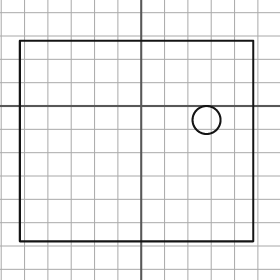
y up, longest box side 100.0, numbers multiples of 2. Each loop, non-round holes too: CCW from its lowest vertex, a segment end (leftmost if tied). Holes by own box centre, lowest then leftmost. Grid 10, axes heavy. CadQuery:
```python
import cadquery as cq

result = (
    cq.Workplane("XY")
    .moveTo(-52.0, -58.0)
    .lineTo(48.0, -58.0)
    .lineTo(48.0, 28.0)
    .lineTo(-52.0, 28.0)
    .close()
    .moveTo(28.0, -6.0)
    .circle(6.0)
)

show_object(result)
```